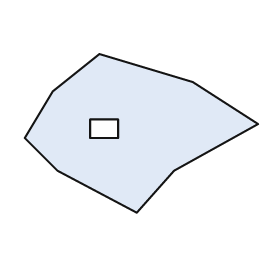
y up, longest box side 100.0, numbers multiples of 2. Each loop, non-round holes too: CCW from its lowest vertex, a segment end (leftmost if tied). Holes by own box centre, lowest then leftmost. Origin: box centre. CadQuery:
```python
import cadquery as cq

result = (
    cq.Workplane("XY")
    .moveTo(-2.0, -34.0)
    .lineTo(14.0, -16.0)
    .lineTo(50.0, 4.0)
    .lineTo(22.0, 22.0)
    .lineTo(-18.0, 34.0)
    .lineTo(-38.0, 18.0)
    .lineTo(-50.0, -2.0)
    .lineTo(-36.0, -16.0)
    .close()
    .moveTo(-22.0, -2.0)
    .lineTo(-10.0, -2.0)
    .lineTo(-10.0, 6.0)
    .lineTo(-22.0, 6.0)
    .close()
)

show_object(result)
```